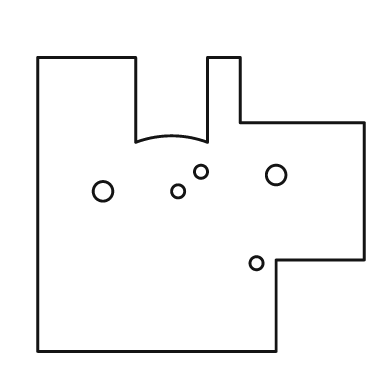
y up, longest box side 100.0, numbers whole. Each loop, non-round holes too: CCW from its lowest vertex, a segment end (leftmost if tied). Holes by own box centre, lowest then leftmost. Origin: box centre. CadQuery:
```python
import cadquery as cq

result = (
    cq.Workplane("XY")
    .moveTo(-50.0, -45.0)
    .lineTo(23.0, -45.0)
    .lineTo(23.0, -17.0)
    .lineTo(50.0, -17.0)
    .lineTo(50.0, 25.0)
    .lineTo(12.0, 25.0)
    .lineTo(12.0, 45.0)
    .lineTo(2.0, 45.0)
    .lineTo(2.0, 19.0)
    .threePointArc((-9.0, 21.0), (-20.0, 19.0))
    .lineTo(-20.0, 45.0)
    .lineTo(-50.0, 45.0)
    .close()
    .moveTo(17.0, -18.0)
    .circle(2.0)
    .moveTo(-30.0, 4.0)
    .circle(3.0)
    .moveTo(-7.0, 4.0)
    .circle(2.0)
    .moveTo(23.0, 9.0)
    .circle(3.0)
    .moveTo(0.0, 10.0)
    .circle(2.0)
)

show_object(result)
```